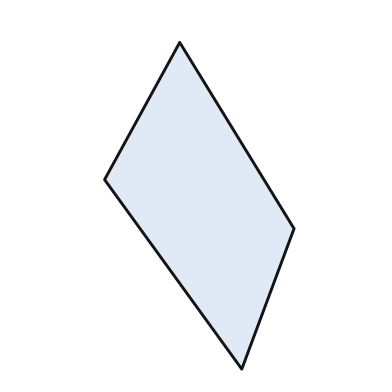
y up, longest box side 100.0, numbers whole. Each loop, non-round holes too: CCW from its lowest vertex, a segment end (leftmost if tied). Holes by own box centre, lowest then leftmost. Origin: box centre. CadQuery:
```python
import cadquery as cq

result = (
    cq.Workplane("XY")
    .moveTo(13.0, -50.0)
    .lineTo(29.0, -7.0)
    .lineTo(-6.0, 50.0)
    .lineTo(-29.0, 8.0)
    .close()
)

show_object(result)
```